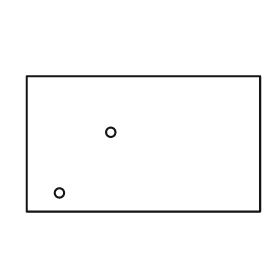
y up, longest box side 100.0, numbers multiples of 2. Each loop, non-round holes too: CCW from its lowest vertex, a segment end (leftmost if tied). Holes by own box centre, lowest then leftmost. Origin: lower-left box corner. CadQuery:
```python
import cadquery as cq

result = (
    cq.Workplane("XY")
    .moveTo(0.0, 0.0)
    .lineTo(100.0, 0.0)
    .lineTo(100.0, 58.0)
    .lineTo(0.0, 58.0)
    .close()
    .moveTo(14.0, 8.0)
    .circle(2.0)
    .moveTo(36.0, 34.0)
    .circle(2.0)
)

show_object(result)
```